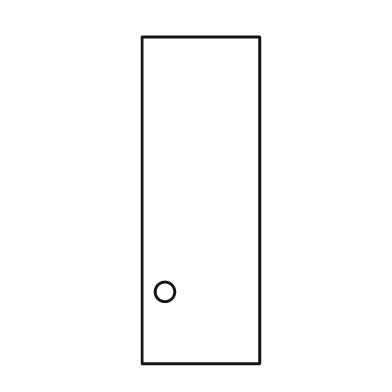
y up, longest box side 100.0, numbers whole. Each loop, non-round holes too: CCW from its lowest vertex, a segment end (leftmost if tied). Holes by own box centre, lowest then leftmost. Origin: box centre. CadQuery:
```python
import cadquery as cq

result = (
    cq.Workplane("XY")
    .moveTo(-18.0, -50.0)
    .lineTo(18.0, -50.0)
    .lineTo(18.0, 50.0)
    .lineTo(-18.0, 50.0)
    .close()
    .moveTo(-11.0, -28.0)
    .circle(3.0)
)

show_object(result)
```